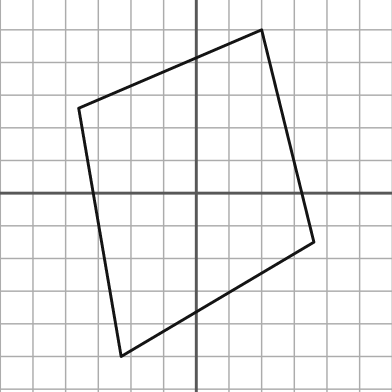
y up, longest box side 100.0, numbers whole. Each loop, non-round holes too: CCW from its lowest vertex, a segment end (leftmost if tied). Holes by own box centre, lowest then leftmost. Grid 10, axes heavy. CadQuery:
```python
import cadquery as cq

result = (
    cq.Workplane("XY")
    .moveTo(-23.0, -50.0)
    .lineTo(36.0, -15.0)
    .lineTo(20.0, 50.0)
    .lineTo(-36.0, 26.0)
    .close()
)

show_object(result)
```